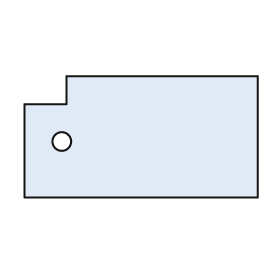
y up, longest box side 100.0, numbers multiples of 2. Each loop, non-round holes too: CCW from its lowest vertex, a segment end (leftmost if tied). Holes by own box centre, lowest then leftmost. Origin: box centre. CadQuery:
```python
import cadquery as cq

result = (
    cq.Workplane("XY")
    .moveTo(-50.0, -26.0)
    .lineTo(50.0, -26.0)
    .lineTo(50.0, 26.0)
    .lineTo(-32.0, 26.0)
    .lineTo(-32.0, 14.0)
    .lineTo(-50.0, 14.0)
    .close()
    .moveTo(-34.0, -2.0)
    .circle(4.0)
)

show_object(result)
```